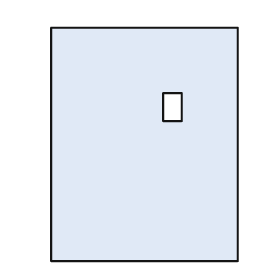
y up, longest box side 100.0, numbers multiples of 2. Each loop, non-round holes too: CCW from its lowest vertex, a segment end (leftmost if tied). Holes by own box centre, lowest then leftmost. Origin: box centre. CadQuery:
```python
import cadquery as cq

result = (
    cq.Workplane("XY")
    .moveTo(-40.0, -50.0)
    .lineTo(40.0, -50.0)
    .lineTo(40.0, 50.0)
    .lineTo(-40.0, 50.0)
    .close()
    .moveTo(8.0, 10.0)
    .lineTo(16.0, 10.0)
    .lineTo(16.0, 22.0)
    .lineTo(8.0, 22.0)
    .close()
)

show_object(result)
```